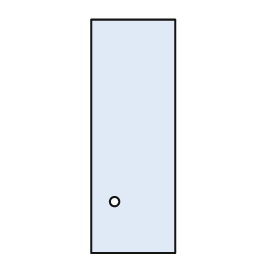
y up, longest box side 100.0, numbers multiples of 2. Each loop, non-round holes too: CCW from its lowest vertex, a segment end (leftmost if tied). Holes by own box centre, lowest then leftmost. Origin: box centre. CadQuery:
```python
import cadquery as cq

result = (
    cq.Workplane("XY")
    .moveTo(-18.0, -50.0)
    .lineTo(18.0, -50.0)
    .lineTo(18.0, 50.0)
    .lineTo(-18.0, 50.0)
    .close()
    .moveTo(-8.0, -28.0)
    .circle(2.0)
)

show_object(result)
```